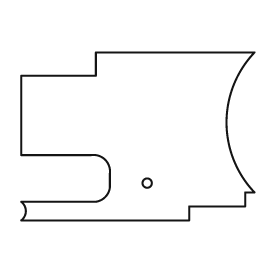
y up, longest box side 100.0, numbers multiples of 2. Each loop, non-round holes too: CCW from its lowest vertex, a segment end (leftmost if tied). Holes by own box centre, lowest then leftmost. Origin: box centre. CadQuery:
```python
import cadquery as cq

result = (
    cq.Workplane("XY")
    .moveTo(-50.0, -36.0)
    .lineTo(22.0, -36.0)
    .lineTo(22.0, -30.0)
    .lineTo(46.0, -30.0)
    .lineTo(46.0, -24.0)
    .lineTo(50.0, -24.0)
    .threePointArc((38.0, 6.0), (50.0, 36.0))
    .lineTo(-18.0, 36.0)
    .lineTo(-18.0, 26.0)
    .lineTo(-50.0, 26.0)
    .lineTo(-50.0, -8.0)
    .lineTo(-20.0, -8.0)
    .threePointArc((-14.0, -10.0), (-12.0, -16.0))
    .lineTo(-12.0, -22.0)
    .threePointArc((-14.0, -26.0), (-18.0, -28.0))
    .lineTo(-50.0, -28.0)
    .threePointArc((-48.0, -32.0), (-50.0, -36.0))
    .close()
    .moveTo(4.0, -20.0)
    .circle(2.0)
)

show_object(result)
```